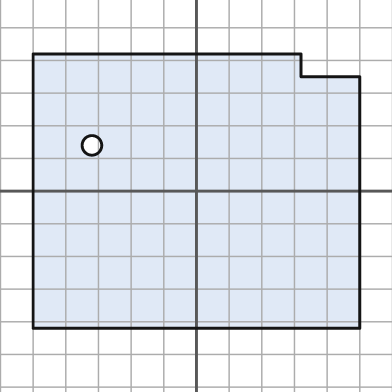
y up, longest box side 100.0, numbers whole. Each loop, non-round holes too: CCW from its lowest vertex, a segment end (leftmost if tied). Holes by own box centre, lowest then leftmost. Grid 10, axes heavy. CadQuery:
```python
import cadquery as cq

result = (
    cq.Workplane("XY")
    .moveTo(-50.0, -42.0)
    .lineTo(50.0, -42.0)
    .lineTo(50.0, 35.0)
    .lineTo(32.0, 35.0)
    .lineTo(32.0, 42.0)
    .lineTo(-50.0, 42.0)
    .close()
    .moveTo(-32.0, 14.0)
    .circle(3.0)
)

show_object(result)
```